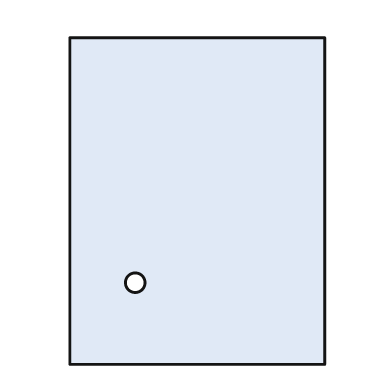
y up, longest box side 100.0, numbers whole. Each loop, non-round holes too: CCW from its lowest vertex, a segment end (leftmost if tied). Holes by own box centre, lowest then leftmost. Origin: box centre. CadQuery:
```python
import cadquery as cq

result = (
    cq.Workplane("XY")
    .moveTo(-39.0, -50.0)
    .lineTo(39.0, -50.0)
    .lineTo(39.0, 50.0)
    .lineTo(-39.0, 50.0)
    .close()
    .moveTo(-19.0, -25.0)
    .circle(3.0)
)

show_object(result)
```